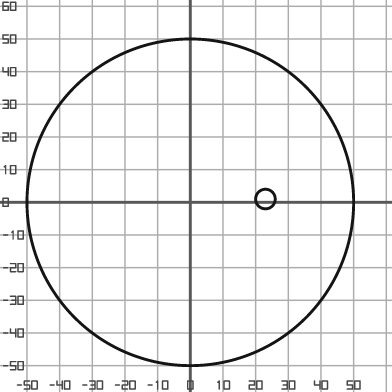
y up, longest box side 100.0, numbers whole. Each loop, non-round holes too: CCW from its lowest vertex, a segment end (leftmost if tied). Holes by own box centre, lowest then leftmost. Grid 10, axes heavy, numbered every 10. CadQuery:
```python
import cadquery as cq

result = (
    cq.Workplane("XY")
    .moveTo(0.0, 0.0)
    .circle(50.0)
    .moveTo(23.0, 1.0)
    .circle(3.0)
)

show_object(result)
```